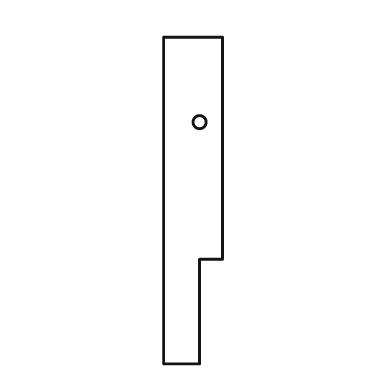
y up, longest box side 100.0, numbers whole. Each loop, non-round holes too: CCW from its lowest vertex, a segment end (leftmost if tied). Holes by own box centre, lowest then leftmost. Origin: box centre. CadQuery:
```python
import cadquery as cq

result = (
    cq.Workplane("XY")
    .moveTo(-9.0, -50.0)
    .lineTo(2.0, -50.0)
    .lineTo(2.0, -18.0)
    .lineTo(9.0, -18.0)
    .lineTo(9.0, 50.0)
    .lineTo(-9.0, 50.0)
    .close()
    .moveTo(2.0, 24.0)
    .circle(2.0)
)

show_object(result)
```